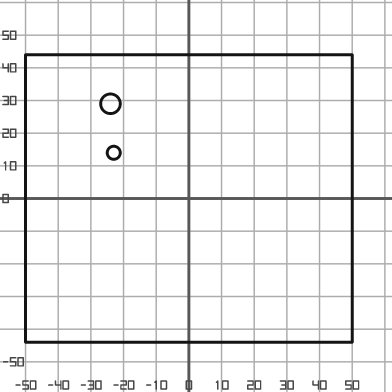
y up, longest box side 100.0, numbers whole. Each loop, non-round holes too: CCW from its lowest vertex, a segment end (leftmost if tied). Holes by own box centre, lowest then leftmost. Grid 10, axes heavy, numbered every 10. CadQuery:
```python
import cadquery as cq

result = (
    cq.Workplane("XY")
    .moveTo(-50.0, -44.0)
    .lineTo(50.0, -44.0)
    .lineTo(50.0, 44.0)
    .lineTo(-50.0, 44.0)
    .close()
    .moveTo(-23.0, 14.0)
    .circle(2.0)
    .moveTo(-24.0, 29.0)
    .circle(3.0)
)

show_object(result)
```